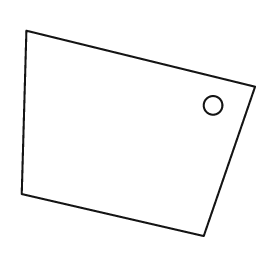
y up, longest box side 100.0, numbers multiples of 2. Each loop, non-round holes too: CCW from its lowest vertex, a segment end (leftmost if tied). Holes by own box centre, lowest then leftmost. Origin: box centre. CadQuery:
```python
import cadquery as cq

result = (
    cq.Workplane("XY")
    .moveTo(28.0, -44.0)
    .lineTo(50.0, 20.0)
    .lineTo(-48.0, 44.0)
    .lineTo(-50.0, -26.0)
    .close()
    .moveTo(32.0, 12.0)
    .circle(4.0)
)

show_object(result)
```